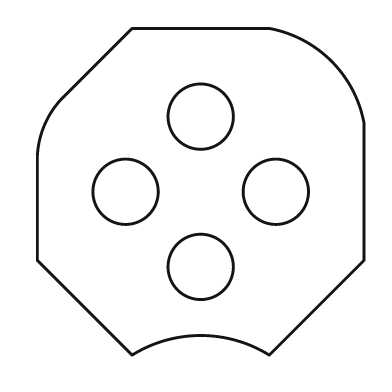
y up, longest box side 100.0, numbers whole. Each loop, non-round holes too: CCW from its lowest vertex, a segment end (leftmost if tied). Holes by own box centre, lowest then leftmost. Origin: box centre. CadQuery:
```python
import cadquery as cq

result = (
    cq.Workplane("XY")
    .moveTo(-21.0, -50.0)
    .threePointArc((0.0, -44.0), (21.0, -50.0))
    .lineTo(50.0, -21.0)
    .lineTo(50.0, 21.0)
    .threePointArc((40.0, 40.0), (21.0, 50.0))
    .lineTo(-21.0, 50.0)
    .lineTo(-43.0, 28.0)
    .threePointArc((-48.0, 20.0), (-50.0, 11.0))
    .lineTo(-50.0, -21.0)
    .close()
    .moveTo(0.0, -23.0)
    .circle(10.0)
    .moveTo(-23.0, 0.0)
    .circle(10.0)
    .moveTo(23.0, 0.0)
    .circle(10.0)
    .moveTo(0.0, 23.0)
    .circle(10.0)
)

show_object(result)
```